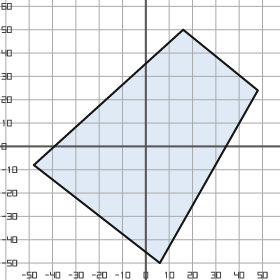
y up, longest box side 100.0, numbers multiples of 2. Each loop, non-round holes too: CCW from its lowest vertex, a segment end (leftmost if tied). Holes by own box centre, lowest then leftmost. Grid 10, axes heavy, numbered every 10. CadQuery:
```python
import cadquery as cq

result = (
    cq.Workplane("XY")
    .moveTo(6.0, -50.0)
    .lineTo(48.0, 24.0)
    .lineTo(16.0, 50.0)
    .lineTo(-48.0, -8.0)
    .close()
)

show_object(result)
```